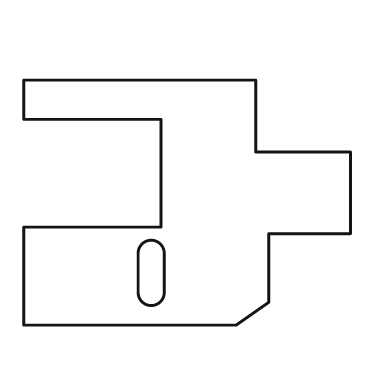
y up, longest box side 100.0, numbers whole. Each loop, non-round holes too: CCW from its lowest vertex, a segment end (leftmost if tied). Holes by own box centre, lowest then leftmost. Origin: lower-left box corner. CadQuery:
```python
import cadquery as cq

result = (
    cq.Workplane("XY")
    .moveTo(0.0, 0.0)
    .lineTo(65.0, 0.0)
    .lineTo(75.0, 7.0)
    .lineTo(75.0, 28.0)
    .lineTo(100.0, 28.0)
    .lineTo(100.0, 53.0)
    .lineTo(71.0, 53.0)
    .lineTo(71.0, 75.0)
    .lineTo(0.0, 75.0)
    .lineTo(0.0, 63.0)
    .lineTo(42.0, 63.0)
    .lineTo(42.0, 30.0)
    .lineTo(0.0, 30.0)
    .close()
    .moveTo(35.0, 10.0)
    .threePointArc((39.0, 6.0), (43.0, 10.0))
    .lineTo(43.0, 22.0)
    .threePointArc((39.0, 26.0), (35.0, 22.0))
    .close()
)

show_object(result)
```